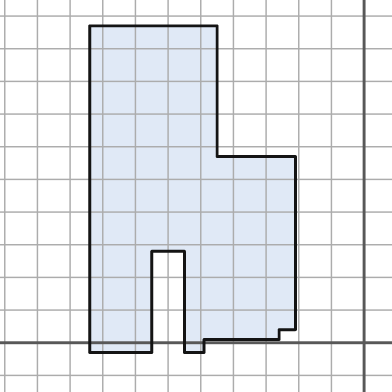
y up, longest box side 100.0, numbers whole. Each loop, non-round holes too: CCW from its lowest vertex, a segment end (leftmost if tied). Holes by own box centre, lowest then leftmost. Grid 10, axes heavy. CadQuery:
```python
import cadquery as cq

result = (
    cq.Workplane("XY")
    .moveTo(-84.0, -3.0)
    .lineTo(-65.0, -3.0)
    .lineTo(-65.0, 28.0)
    .lineTo(-55.0, 28.0)
    .lineTo(-55.0, -3.0)
    .lineTo(-49.0, -3.0)
    .lineTo(-49.0, 1.0)
    .lineTo(-26.0, 1.0)
    .lineTo(-26.0, 4.0)
    .lineTo(-21.0, 4.0)
    .lineTo(-21.0, 57.0)
    .lineTo(-45.0, 57.0)
    .lineTo(-45.0, 97.0)
    .lineTo(-84.0, 97.0)
    .close()
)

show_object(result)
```